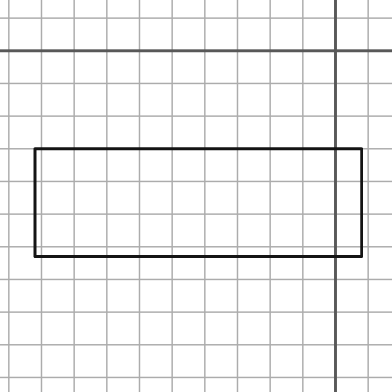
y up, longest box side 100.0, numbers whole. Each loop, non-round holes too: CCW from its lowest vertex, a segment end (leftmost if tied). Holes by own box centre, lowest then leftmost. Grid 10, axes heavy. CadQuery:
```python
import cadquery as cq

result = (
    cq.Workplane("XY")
    .moveTo(-92.0, -63.0)
    .lineTo(8.0, -63.0)
    .lineTo(8.0, -30.0)
    .lineTo(-92.0, -30.0)
    .close()
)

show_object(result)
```